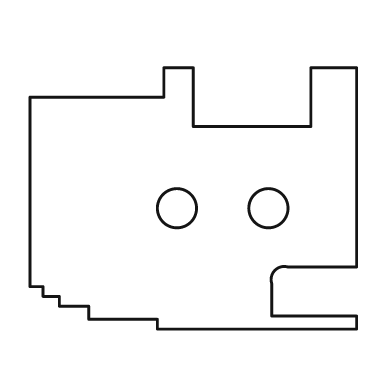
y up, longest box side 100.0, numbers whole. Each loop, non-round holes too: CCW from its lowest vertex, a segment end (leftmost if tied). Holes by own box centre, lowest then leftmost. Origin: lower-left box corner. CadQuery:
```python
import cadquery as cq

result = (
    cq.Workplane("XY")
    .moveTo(39.0, 0.0)
    .lineTo(100.0, 0.0)
    .lineTo(100.0, 4.0)
    .lineTo(74.0, 4.0)
    .lineTo(74.0, 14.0)
    .threePointArc((75.0, 18.0), (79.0, 19.0))
    .lineTo(100.0, 19.0)
    .lineTo(100.0, 80.0)
    .lineTo(86.0, 80.0)
    .lineTo(86.0, 62.0)
    .lineTo(50.0, 62.0)
    .lineTo(50.0, 80.0)
    .lineTo(41.0, 80.0)
    .lineTo(41.0, 71.0)
    .lineTo(0.0, 71.0)
    .lineTo(0.0, 13.0)
    .lineTo(4.0, 13.0)
    .lineTo(4.0, 10.0)
    .lineTo(9.0, 10.0)
    .lineTo(9.0, 7.0)
    .lineTo(18.0, 7.0)
    .lineTo(18.0, 3.0)
    .lineTo(39.0, 3.0)
    .close()
    .moveTo(45.0, 37.0)
    .circle(6.0)
    .moveTo(73.0, 37.0)
    .circle(6.0)
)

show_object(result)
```